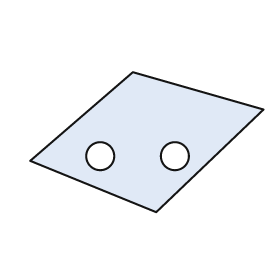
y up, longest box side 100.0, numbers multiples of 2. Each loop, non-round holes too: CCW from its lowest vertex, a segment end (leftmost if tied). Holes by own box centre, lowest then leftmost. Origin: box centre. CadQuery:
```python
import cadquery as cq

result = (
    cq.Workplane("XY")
    .moveTo(4.0, -30.0)
    .lineTo(50.0, 14.0)
    .lineTo(-6.0, 30.0)
    .lineTo(-50.0, -8.0)
    .close()
    .moveTo(-20.0, -6.0)
    .circle(6.0)
    .moveTo(12.0, -6.0)
    .circle(6.0)
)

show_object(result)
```